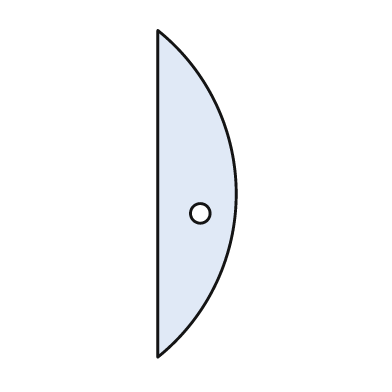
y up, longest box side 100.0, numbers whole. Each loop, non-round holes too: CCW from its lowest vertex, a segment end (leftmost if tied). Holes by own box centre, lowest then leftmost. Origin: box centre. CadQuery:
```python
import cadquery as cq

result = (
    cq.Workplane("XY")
    .moveTo(-12.0, -50.0)
    .threePointArc((12.0, 0.0), (-12.0, 50.0))
    .close()
    .moveTo(1.0, -6.0)
    .circle(3.0)
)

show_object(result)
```